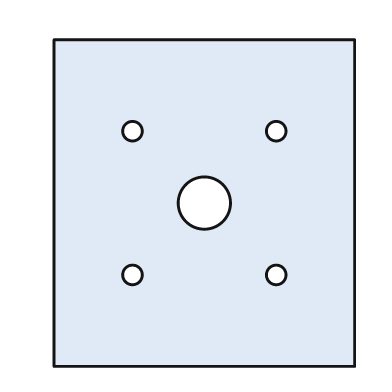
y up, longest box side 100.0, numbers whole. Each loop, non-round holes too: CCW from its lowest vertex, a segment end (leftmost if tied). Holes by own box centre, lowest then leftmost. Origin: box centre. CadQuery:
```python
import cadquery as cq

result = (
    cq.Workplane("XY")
    .moveTo(-46.0, -50.0)
    .lineTo(46.0, -50.0)
    .lineTo(46.0, 50.0)
    .lineTo(-46.0, 50.0)
    .close()
    .moveTo(-22.0, -22.0)
    .circle(3.0)
    .moveTo(22.0, -22.0)
    .circle(3.0)
    .moveTo(0.0, 0.0)
    .circle(8.0)
    .moveTo(-22.0, 22.0)
    .circle(3.0)
    .moveTo(22.0, 22.0)
    .circle(3.0)
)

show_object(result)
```